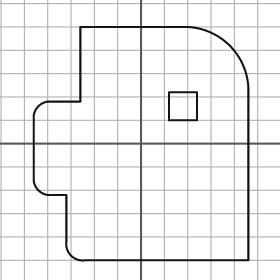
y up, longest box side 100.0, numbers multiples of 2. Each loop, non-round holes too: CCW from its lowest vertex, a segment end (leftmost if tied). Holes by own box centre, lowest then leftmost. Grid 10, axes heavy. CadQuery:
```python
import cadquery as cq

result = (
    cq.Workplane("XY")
    .moveTo(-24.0, -50.0)
    .lineTo(46.0, -50.0)
    .lineTo(46.0, 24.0)
    .threePointArc((38.0, 42.0), (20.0, 50.0))
    .lineTo(-26.0, 50.0)
    .lineTo(-26.0, 18.0)
    .lineTo(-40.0, 18.0)
    .threePointArc((-44.0, 16.0), (-46.0, 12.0))
    .lineTo(-46.0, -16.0)
    .threePointArc((-44.0, -20.0), (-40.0, -22.0))
    .lineTo(-32.0, -22.0)
    .lineTo(-32.0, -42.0)
    .threePointArc((-30.0, -48.0), (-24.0, -50.0))
    .close()
    .moveTo(12.0, 10.0)
    .lineTo(24.0, 10.0)
    .lineTo(24.0, 22.0)
    .lineTo(12.0, 22.0)
    .close()
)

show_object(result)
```